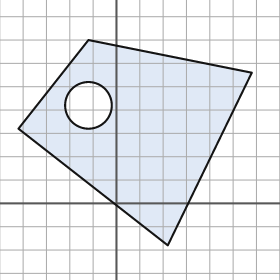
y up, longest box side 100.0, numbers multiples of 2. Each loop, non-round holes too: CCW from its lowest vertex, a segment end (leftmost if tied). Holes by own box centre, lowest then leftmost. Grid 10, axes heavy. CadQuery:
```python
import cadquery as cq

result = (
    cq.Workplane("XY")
    .moveTo(22.0, -18.0)
    .lineTo(58.0, 56.0)
    .lineTo(-12.0, 70.0)
    .lineTo(-42.0, 32.0)
    .close()
    .moveTo(-12.0, 42.0)
    .circle(10.0)
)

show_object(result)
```